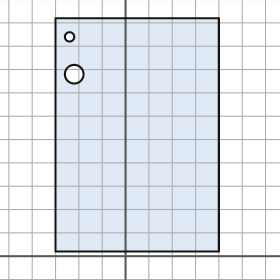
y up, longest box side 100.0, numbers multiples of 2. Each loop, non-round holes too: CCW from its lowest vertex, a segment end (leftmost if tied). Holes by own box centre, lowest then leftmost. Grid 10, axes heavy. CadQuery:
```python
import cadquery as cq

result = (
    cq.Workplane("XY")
    .moveTo(-30.0, 2.0)
    .lineTo(40.0, 2.0)
    .lineTo(40.0, 102.0)
    .lineTo(-30.0, 102.0)
    .close()
    .moveTo(-22.0, 78.0)
    .circle(4.0)
    .moveTo(-24.0, 94.0)
    .circle(2.0)
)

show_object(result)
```